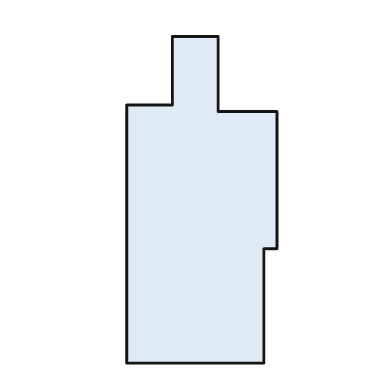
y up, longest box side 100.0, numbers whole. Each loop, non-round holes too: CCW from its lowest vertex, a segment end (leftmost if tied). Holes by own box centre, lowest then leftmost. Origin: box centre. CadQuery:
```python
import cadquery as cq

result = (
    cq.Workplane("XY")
    .moveTo(-23.0, -50.0)
    .lineTo(19.0, -50.0)
    .lineTo(19.0, -15.0)
    .lineTo(23.0, -15.0)
    .lineTo(23.0, 27.0)
    .lineTo(5.0, 27.0)
    .lineTo(5.0, 50.0)
    .lineTo(-9.0, 50.0)
    .lineTo(-9.0, 29.0)
    .lineTo(-23.0, 29.0)
    .close()
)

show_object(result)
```